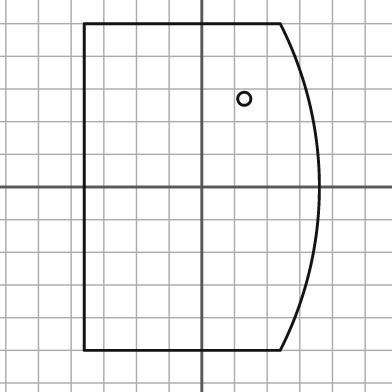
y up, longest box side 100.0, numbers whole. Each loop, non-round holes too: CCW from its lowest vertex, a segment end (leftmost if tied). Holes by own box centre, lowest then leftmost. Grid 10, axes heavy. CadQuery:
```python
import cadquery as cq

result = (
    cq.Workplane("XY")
    .moveTo(-36.0, -50.0)
    .lineTo(24.0, -50.0)
    .threePointArc((36.0, 0.0), (24.0, 50.0))
    .lineTo(-36.0, 50.0)
    .close()
    .moveTo(13.0, 27.0)
    .circle(2.0)
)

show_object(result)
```